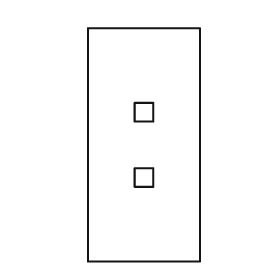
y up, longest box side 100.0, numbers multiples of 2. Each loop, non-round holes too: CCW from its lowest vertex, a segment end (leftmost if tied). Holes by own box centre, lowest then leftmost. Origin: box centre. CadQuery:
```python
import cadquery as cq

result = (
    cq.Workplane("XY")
    .moveTo(-24.0, -50.0)
    .lineTo(24.0, -50.0)
    .lineTo(24.0, 50.0)
    .lineTo(-24.0, 50.0)
    .close()
    .moveTo(-4.0, -18.0)
    .lineTo(4.0, -18.0)
    .lineTo(4.0, -10.0)
    .lineTo(-4.0, -10.0)
    .close()
    .moveTo(-4.0, 10.0)
    .lineTo(4.0, 10.0)
    .lineTo(4.0, 18.0)
    .lineTo(-4.0, 18.0)
    .close()
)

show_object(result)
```